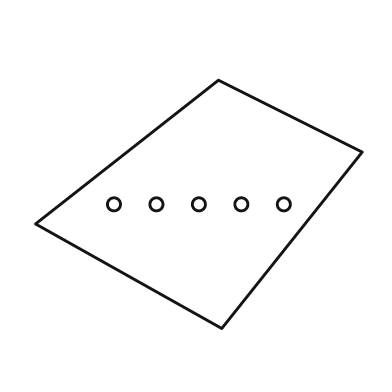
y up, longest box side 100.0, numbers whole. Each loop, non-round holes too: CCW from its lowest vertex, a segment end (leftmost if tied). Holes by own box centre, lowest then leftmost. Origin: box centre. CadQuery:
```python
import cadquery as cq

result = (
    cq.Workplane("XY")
    .moveTo(7.0, -38.0)
    .lineTo(50.0, 16.0)
    .lineTo(6.0, 38.0)
    .lineTo(-50.0, -6.0)
    .close()
    .moveTo(-26.0, 0.0)
    .circle(2.0)
    .moveTo(-13.0, 0.0)
    .circle(2.0)
    .moveTo(0.0, 0.0)
    .circle(2.0)
    .moveTo(13.0, 0.0)
    .circle(2.0)
    .moveTo(26.0, 0.0)
    .circle(2.0)
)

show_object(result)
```